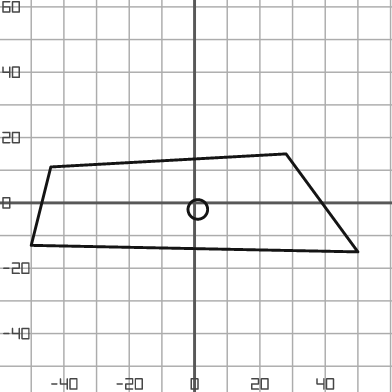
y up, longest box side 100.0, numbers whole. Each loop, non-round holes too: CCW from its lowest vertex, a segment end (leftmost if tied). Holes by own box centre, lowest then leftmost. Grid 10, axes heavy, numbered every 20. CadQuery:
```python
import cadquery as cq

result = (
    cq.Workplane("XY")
    .moveTo(50.0, -15.0)
    .lineTo(28.0, 15.0)
    .lineTo(-44.0, 11.0)
    .lineTo(-50.0, -13.0)
    .close()
    .moveTo(1.0, -2.0)
    .circle(3.0)
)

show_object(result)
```